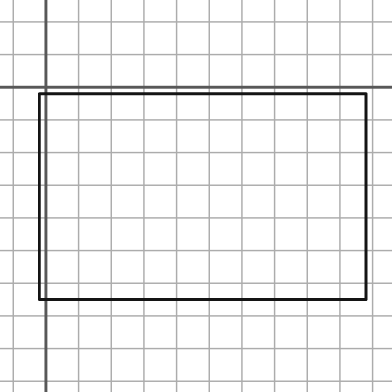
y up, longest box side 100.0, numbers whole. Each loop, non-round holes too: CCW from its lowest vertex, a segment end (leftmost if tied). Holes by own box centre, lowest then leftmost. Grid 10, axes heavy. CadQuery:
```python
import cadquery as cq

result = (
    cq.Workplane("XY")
    .moveTo(-2.0, -65.0)
    .lineTo(98.0, -65.0)
    .lineTo(98.0, -2.0)
    .lineTo(-2.0, -2.0)
    .close()
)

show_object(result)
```